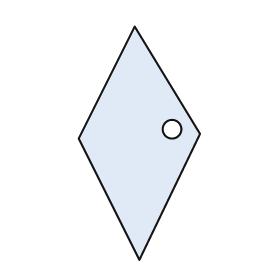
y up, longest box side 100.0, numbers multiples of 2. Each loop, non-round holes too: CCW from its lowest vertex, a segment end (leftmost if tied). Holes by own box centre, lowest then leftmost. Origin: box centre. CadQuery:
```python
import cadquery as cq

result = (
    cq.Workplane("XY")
    .moveTo(0.0, -50.0)
    .lineTo(26.0, 4.0)
    .lineTo(-2.0, 50.0)
    .lineTo(-26.0, 2.0)
    .close()
    .moveTo(14.0, 6.0)
    .circle(4.0)
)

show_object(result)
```